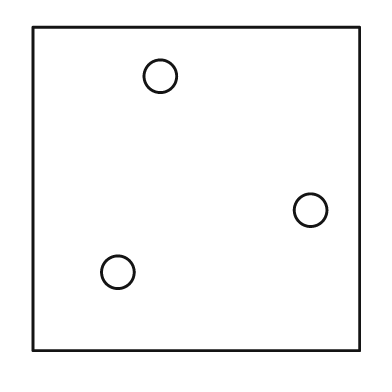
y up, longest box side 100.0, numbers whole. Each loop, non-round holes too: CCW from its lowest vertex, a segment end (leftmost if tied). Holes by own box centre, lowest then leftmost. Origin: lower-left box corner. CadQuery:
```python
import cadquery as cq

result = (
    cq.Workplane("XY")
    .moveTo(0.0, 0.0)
    .lineTo(100.0, 0.0)
    .lineTo(100.0, 99.0)
    .lineTo(0.0, 99.0)
    .close()
    .moveTo(26.0, 24.0)
    .circle(5.0)
    .moveTo(85.0, 43.0)
    .circle(5.0)
    .moveTo(39.0, 84.0)
    .circle(5.0)
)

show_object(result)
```